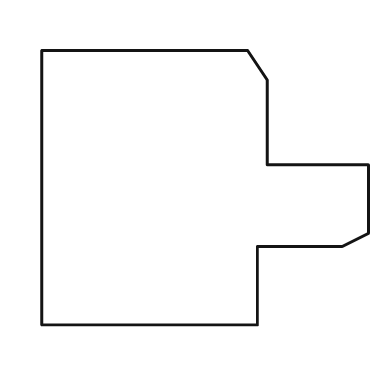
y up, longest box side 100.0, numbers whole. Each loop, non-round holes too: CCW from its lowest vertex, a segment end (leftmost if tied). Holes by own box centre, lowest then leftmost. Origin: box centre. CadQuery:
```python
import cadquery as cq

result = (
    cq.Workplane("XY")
    .moveTo(-50.0, -42.0)
    .lineTo(16.0, -42.0)
    .lineTo(16.0, -18.0)
    .lineTo(42.0, -18.0)
    .lineTo(50.0, -14.0)
    .lineTo(50.0, 7.0)
    .lineTo(19.0, 7.0)
    .lineTo(19.0, 33.0)
    .lineTo(13.0, 42.0)
    .lineTo(-50.0, 42.0)
    .close()
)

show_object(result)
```